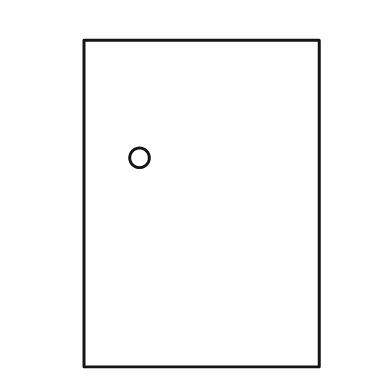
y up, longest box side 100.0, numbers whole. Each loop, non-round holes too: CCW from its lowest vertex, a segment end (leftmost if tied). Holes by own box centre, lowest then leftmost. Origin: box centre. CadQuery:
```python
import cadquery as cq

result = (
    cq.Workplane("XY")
    .moveTo(-36.0, -50.0)
    .lineTo(36.0, -50.0)
    .lineTo(36.0, 50.0)
    .lineTo(-36.0, 50.0)
    .close()
    .moveTo(-19.0, 14.0)
    .circle(3.0)
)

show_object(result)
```